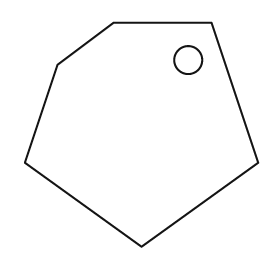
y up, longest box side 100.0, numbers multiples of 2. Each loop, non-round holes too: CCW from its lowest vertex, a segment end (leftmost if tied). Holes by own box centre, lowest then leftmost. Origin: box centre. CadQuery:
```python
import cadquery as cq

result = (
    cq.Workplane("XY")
    .moveTo(0.0, -48.0)
    .lineTo(50.0, -12.0)
    .lineTo(30.0, 48.0)
    .lineTo(-12.0, 48.0)
    .lineTo(-36.0, 30.0)
    .lineTo(-50.0, -12.0)
    .close()
    .moveTo(20.0, 32.0)
    .circle(6.0)
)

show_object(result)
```